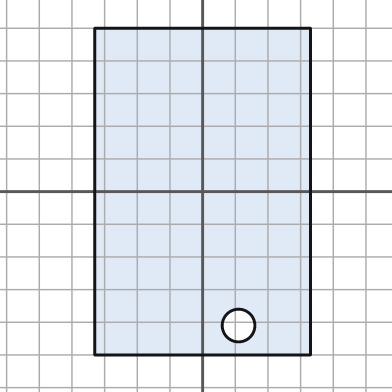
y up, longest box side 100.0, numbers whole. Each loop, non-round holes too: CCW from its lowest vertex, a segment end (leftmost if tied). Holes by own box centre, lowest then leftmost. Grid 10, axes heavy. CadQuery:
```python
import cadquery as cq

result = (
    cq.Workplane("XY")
    .moveTo(-33.0, -50.0)
    .lineTo(33.0, -50.0)
    .lineTo(33.0, 50.0)
    .lineTo(-33.0, 50.0)
    .close()
    .moveTo(11.0, -41.0)
    .circle(5.0)
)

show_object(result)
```